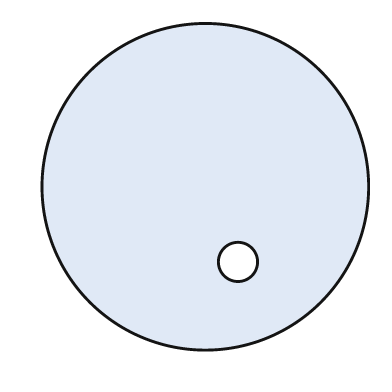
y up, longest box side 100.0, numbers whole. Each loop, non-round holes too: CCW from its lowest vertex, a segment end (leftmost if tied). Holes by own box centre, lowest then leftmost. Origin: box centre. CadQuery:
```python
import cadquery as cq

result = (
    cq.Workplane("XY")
    .moveTo(0.0, 0.0)
    .circle(50.0)
    .moveTo(10.0, -23.0)
    .circle(6.0)
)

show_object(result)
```